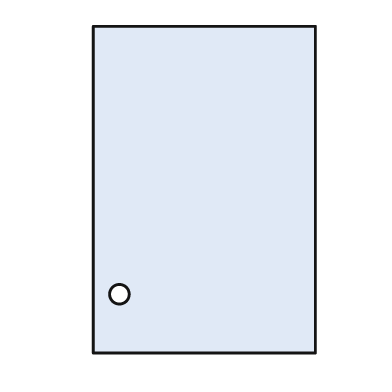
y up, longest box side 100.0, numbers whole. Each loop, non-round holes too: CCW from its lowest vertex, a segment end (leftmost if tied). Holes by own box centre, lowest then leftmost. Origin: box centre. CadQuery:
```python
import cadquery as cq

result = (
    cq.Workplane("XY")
    .moveTo(-34.0, -50.0)
    .lineTo(34.0, -50.0)
    .lineTo(34.0, 50.0)
    .lineTo(-34.0, 50.0)
    .close()
    .moveTo(-26.0, -32.0)
    .circle(3.0)
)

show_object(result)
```